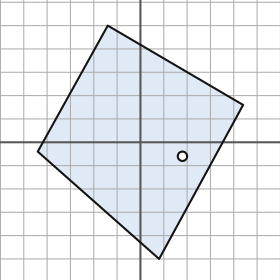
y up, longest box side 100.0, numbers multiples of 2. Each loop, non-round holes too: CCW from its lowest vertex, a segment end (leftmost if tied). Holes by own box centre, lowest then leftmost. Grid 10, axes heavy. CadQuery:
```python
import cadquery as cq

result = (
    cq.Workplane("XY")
    .moveTo(8.0, -50.0)
    .lineTo(44.0, 16.0)
    .lineTo(-14.0, 50.0)
    .lineTo(-44.0, -4.0)
    .close()
    .moveTo(18.0, -6.0)
    .circle(2.0)
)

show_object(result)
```